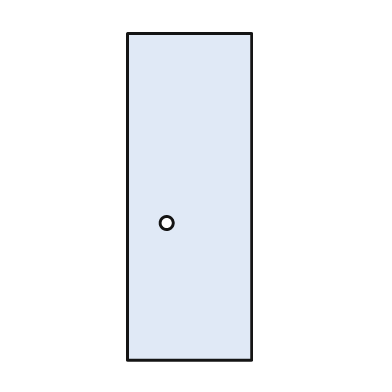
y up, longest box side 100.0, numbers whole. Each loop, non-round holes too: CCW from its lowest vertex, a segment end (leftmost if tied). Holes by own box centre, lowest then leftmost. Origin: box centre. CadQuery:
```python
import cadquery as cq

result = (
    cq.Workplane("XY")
    .moveTo(-19.0, -50.0)
    .lineTo(19.0, -50.0)
    .lineTo(19.0, 50.0)
    .lineTo(-19.0, 50.0)
    .close()
    .moveTo(-7.0, -8.0)
    .circle(2.0)
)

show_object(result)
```